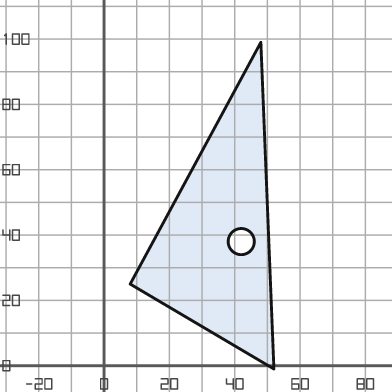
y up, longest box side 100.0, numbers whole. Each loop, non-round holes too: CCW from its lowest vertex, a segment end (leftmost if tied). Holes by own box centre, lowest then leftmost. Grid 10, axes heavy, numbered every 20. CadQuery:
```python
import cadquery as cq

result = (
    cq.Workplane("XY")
    .moveTo(52.0, -1.0)
    .lineTo(48.0, 99.0)
    .lineTo(8.0, 25.0)
    .close()
    .moveTo(42.0, 38.0)
    .circle(4.0)
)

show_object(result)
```